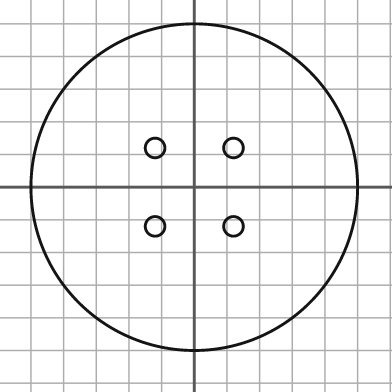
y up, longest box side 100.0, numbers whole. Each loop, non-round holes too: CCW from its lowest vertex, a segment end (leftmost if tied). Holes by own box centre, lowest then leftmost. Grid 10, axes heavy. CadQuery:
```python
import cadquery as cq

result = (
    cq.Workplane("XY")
    .moveTo(0.0, 0.0)
    .circle(50.0)
    .moveTo(-12.0, -12.0)
    .circle(3.0)
    .moveTo(12.0, -12.0)
    .circle(3.0)
    .moveTo(-12.0, 12.0)
    .circle(3.0)
    .moveTo(12.0, 12.0)
    .circle(3.0)
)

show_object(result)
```